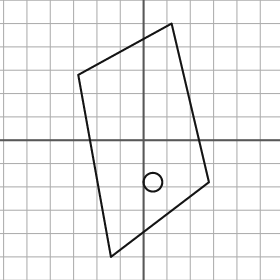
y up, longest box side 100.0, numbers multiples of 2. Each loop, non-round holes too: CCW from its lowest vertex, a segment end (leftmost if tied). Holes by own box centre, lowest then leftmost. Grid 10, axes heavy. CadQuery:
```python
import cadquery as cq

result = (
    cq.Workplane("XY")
    .moveTo(-14.0, -50.0)
    .lineTo(28.0, -18.0)
    .lineTo(12.0, 50.0)
    .lineTo(-28.0, 28.0)
    .close()
    .moveTo(4.0, -18.0)
    .circle(4.0)
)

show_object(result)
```